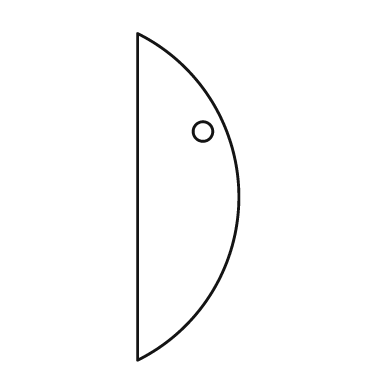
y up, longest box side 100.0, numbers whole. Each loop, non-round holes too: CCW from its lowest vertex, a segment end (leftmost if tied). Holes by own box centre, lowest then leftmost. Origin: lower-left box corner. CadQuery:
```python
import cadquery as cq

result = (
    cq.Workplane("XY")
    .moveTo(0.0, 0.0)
    .threePointArc((31.0, 50.0), (0.0, 100.0))
    .close()
    .moveTo(20.0, 70.0)
    .circle(3.0)
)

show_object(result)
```